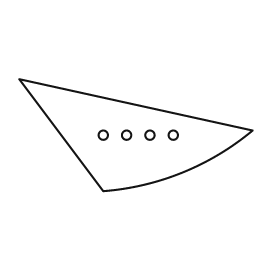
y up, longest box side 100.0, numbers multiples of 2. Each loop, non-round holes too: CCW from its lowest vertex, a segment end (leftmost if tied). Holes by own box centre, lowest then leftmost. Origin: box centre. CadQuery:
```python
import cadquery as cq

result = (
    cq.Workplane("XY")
    .moveTo(-14.0, -24.0)
    .threePointArc((20.0, -16.0), (50.0, 2.0))
    .lineTo(-50.0, 24.0)
    .close()
    .moveTo(-14.0, 0.0)
    .circle(2.0)
    .moveTo(-4.0, 0.0)
    .circle(2.0)
    .moveTo(6.0, 0.0)
    .circle(2.0)
    .moveTo(16.0, 0.0)
    .circle(2.0)
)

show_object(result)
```